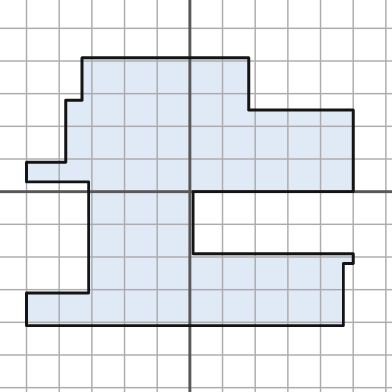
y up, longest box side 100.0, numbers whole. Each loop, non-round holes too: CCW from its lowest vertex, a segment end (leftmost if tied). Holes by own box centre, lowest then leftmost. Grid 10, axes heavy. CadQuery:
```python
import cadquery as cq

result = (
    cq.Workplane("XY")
    .moveTo(-50.0, -41.0)
    .lineTo(47.0, -41.0)
    .lineTo(47.0, -22.0)
    .lineTo(50.0, -22.0)
    .lineTo(50.0, -19.0)
    .lineTo(1.0, -19.0)
    .lineTo(1.0, 0.0)
    .lineTo(50.0, 0.0)
    .lineTo(50.0, 25.0)
    .lineTo(18.0, 25.0)
    .lineTo(18.0, 41.0)
    .lineTo(-33.0, 41.0)
    .lineTo(-33.0, 28.0)
    .lineTo(-38.0, 28.0)
    .lineTo(-38.0, 9.0)
    .lineTo(-50.0, 9.0)
    .lineTo(-50.0, 3.0)
    .lineTo(-31.0, 3.0)
    .lineTo(-31.0, -31.0)
    .lineTo(-50.0, -31.0)
    .close()
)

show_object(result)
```